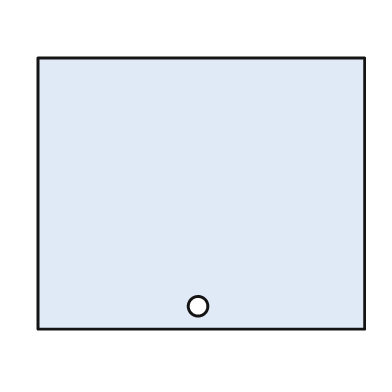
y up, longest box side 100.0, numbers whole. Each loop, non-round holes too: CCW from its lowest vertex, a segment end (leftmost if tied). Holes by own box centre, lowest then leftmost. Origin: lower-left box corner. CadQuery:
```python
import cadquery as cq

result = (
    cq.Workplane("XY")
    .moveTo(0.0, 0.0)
    .lineTo(100.0, 0.0)
    .lineTo(100.0, 83.0)
    .lineTo(0.0, 83.0)
    .close()
    .moveTo(49.0, 7.0)
    .circle(3.0)
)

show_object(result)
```